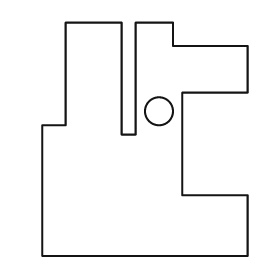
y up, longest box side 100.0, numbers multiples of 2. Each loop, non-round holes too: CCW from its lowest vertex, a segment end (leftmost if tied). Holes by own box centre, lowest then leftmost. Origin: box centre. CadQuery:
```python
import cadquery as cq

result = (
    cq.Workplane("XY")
    .moveTo(-44.0, -50.0)
    .lineTo(44.0, -50.0)
    .lineTo(44.0, -24.0)
    .lineTo(16.0, -24.0)
    .lineTo(16.0, 20.0)
    .lineTo(44.0, 20.0)
    .lineTo(44.0, 40.0)
    .lineTo(12.0, 40.0)
    .lineTo(12.0, 50.0)
    .lineTo(-4.0, 50.0)
    .lineTo(-4.0, 2.0)
    .lineTo(-10.0, 2.0)
    .lineTo(-10.0, 50.0)
    .lineTo(-34.0, 50.0)
    .lineTo(-34.0, 6.0)
    .lineTo(-44.0, 6.0)
    .close()
    .moveTo(6.0, 12.0)
    .circle(6.0)
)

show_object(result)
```